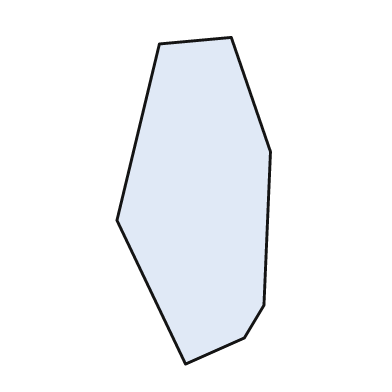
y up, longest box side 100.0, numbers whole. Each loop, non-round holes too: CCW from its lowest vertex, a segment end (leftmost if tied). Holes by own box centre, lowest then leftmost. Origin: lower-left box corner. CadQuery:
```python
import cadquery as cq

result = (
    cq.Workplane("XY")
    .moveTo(21.0, 0.0)
    .lineTo(39.0, 8.0)
    .lineTo(45.0, 18.0)
    .lineTo(47.0, 65.0)
    .lineTo(35.0, 100.0)
    .lineTo(13.0, 98.0)
    .lineTo(0.0, 44.0)
    .close()
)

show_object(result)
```